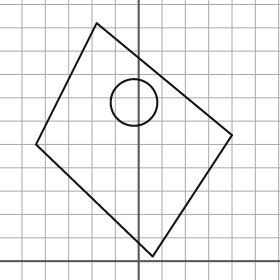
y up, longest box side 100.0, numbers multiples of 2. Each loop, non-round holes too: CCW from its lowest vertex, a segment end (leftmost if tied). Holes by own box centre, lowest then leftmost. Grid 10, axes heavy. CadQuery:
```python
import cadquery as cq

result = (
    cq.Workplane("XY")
    .moveTo(6.0, 2.0)
    .lineTo(40.0, 54.0)
    .lineTo(-18.0, 102.0)
    .lineTo(-44.0, 50.0)
    .close()
    .moveTo(-2.0, 68.0)
    .circle(10.0)
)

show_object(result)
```